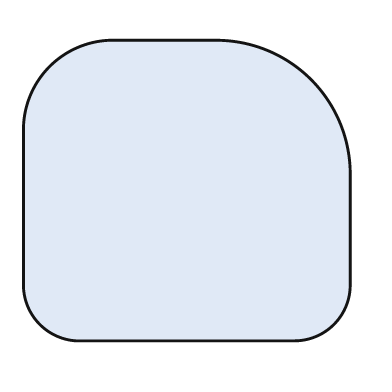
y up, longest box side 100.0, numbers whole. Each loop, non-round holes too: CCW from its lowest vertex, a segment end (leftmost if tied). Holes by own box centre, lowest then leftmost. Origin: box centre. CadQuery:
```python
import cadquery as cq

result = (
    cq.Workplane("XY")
    .moveTo(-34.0, -46.0)
    .lineTo(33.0, -46.0)
    .threePointArc((45.0, -41.0), (50.0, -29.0))
    .lineTo(50.0, 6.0)
    .threePointArc((38.0, 34.0), (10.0, 46.0))
    .lineTo(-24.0, 46.0)
    .threePointArc((-42.0, 38.0), (-50.0, 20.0))
    .lineTo(-50.0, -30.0)
    .threePointArc((-45.0, -41.0), (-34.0, -46.0))
    .close()
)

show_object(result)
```